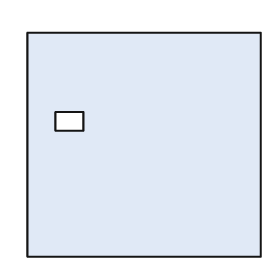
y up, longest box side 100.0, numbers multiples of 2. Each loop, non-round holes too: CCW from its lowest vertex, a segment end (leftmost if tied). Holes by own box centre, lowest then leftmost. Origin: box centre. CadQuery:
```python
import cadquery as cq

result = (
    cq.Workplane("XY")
    .moveTo(-50.0, -48.0)
    .lineTo(50.0, -48.0)
    .lineTo(50.0, 48.0)
    .lineTo(-50.0, 48.0)
    .close()
    .moveTo(-38.0, 6.0)
    .lineTo(-26.0, 6.0)
    .lineTo(-26.0, 14.0)
    .lineTo(-38.0, 14.0)
    .close()
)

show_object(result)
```